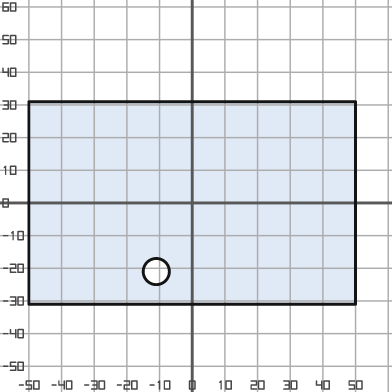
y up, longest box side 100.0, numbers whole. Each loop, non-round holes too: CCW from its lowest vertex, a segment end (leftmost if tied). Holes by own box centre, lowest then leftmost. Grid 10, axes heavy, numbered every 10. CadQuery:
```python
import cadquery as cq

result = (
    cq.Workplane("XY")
    .moveTo(-50.0, -31.0)
    .lineTo(50.0, -31.0)
    .lineTo(50.0, 31.0)
    .lineTo(-50.0, 31.0)
    .close()
    .moveTo(-11.0, -21.0)
    .circle(4.0)
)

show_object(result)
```